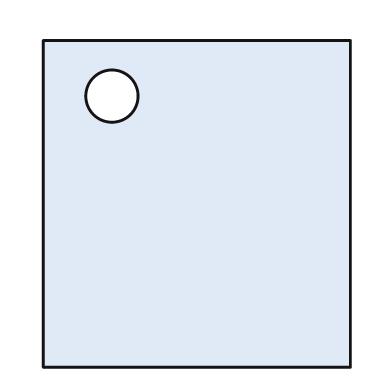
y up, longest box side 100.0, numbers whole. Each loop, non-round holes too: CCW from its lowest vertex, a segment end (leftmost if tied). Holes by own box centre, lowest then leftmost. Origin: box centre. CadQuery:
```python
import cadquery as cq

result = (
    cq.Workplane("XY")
    .moveTo(-47.0, -50.0)
    .lineTo(47.0, -50.0)
    .lineTo(47.0, 50.0)
    .lineTo(-47.0, 50.0)
    .close()
    .moveTo(-26.0, 33.0)
    .circle(8.0)
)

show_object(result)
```